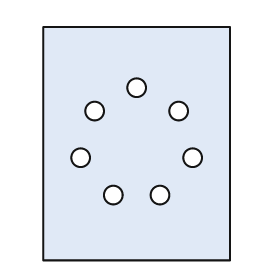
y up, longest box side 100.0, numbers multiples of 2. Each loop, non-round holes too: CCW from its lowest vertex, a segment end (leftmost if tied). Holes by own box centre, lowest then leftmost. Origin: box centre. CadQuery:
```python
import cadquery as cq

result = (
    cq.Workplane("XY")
    .moveTo(-40.0, -50.0)
    .lineTo(40.0, -50.0)
    .lineTo(40.0, 50.0)
    .lineTo(-40.0, 50.0)
    .close()
    .moveTo(-10.0, -22.0)
    .circle(4.0)
    .moveTo(10.0, -22.0)
    .circle(4.0)
    .moveTo(-24.0, -6.0)
    .circle(4.0)
    .moveTo(24.0, -6.0)
    .circle(4.0)
    .moveTo(-18.0, 14.0)
    .circle(4.0)
    .moveTo(18.0, 14.0)
    .circle(4.0)
    .moveTo(0.0, 24.0)
    .circle(4.0)
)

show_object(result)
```